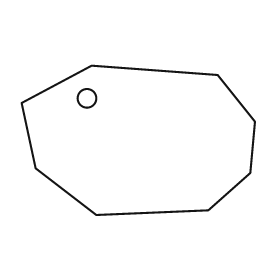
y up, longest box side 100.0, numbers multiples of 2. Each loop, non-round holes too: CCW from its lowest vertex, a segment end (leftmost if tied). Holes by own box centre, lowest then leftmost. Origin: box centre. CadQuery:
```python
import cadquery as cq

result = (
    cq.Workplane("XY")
    .moveTo(-18.0, -32.0)
    .lineTo(30.0, -30.0)
    .lineTo(48.0, -14.0)
    .lineTo(50.0, 8.0)
    .lineTo(34.0, 28.0)
    .lineTo(-20.0, 32.0)
    .lineTo(-50.0, 16.0)
    .lineTo(-44.0, -12.0)
    .close()
    .moveTo(-22.0, 18.0)
    .circle(4.0)
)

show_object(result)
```